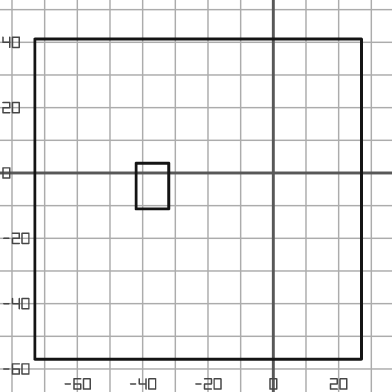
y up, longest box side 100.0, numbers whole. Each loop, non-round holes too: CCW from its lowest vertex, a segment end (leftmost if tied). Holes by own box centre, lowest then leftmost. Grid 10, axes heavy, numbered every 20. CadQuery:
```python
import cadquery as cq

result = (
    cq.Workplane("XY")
    .moveTo(-73.0, -57.0)
    .lineTo(27.0, -57.0)
    .lineTo(27.0, 41.0)
    .lineTo(-73.0, 41.0)
    .close()
    .moveTo(-42.0, -11.0)
    .lineTo(-32.0, -11.0)
    .lineTo(-32.0, 3.0)
    .lineTo(-42.0, 3.0)
    .close()
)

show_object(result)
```